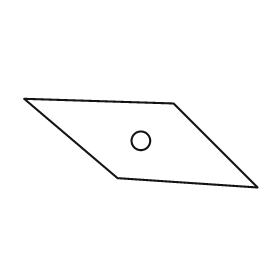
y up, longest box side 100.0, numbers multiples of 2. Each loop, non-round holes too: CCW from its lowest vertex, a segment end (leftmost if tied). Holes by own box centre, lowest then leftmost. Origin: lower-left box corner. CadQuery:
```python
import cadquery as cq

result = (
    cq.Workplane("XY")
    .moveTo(100.0, 0.0)
    .lineTo(64.0, 36.0)
    .lineTo(0.0, 38.0)
    .lineTo(40.0, 4.0)
    .close()
    .moveTo(50.0, 20.0)
    .circle(4.0)
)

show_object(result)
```